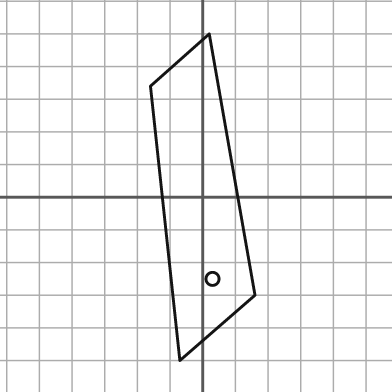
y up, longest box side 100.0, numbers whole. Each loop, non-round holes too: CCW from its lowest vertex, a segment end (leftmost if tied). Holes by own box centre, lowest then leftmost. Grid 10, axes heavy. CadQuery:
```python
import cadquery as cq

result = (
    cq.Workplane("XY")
    .moveTo(-7.0, -50.0)
    .lineTo(16.0, -30.0)
    .lineTo(2.0, 50.0)
    .lineTo(-16.0, 34.0)
    .close()
    .moveTo(3.0, -25.0)
    .circle(2.0)
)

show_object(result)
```